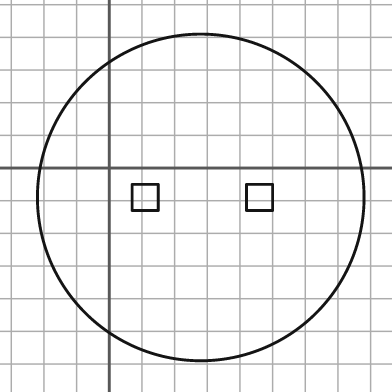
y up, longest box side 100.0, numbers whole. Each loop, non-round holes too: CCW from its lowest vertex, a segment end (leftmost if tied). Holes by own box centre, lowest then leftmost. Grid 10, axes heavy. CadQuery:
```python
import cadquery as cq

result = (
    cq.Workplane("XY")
    .moveTo(28.0, -9.0)
    .circle(50.0)
    .moveTo(7.0, -13.0)
    .lineTo(15.0, -13.0)
    .lineTo(15.0, -5.0)
    .lineTo(7.0, -5.0)
    .close()
    .moveTo(42.0, -13.0)
    .lineTo(50.0, -13.0)
    .lineTo(50.0, -5.0)
    .lineTo(42.0, -5.0)
    .close()
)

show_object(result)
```